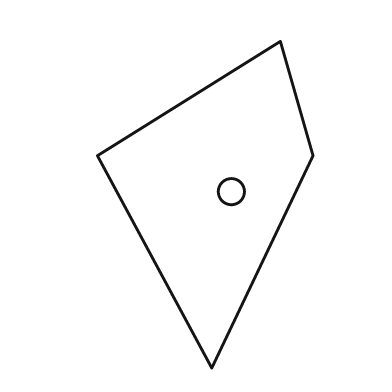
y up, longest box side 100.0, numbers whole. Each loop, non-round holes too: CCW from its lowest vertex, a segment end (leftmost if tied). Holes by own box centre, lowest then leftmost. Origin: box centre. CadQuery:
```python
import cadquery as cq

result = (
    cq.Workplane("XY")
    .moveTo(2.0, -50.0)
    .lineTo(33.0, 15.0)
    .lineTo(23.0, 50.0)
    .lineTo(-33.0, 15.0)
    .close()
    .moveTo(8.0, 4.0)
    .circle(4.0)
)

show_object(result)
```